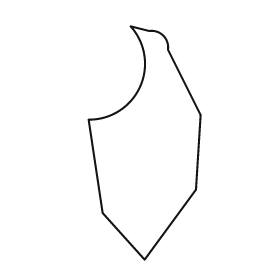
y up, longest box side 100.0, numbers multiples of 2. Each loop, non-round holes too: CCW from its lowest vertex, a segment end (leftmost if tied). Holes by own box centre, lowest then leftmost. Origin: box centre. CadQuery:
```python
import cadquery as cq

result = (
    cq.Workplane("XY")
    .moveTo(0.0, -50.0)
    .lineTo(22.0, -20.0)
    .lineTo(24.0, 12.0)
    .lineTo(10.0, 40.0)
    .threePointArc((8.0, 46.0), (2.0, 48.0))
    .lineTo(-6.0, 50.0)
    .threePointArc((-2.0, 24.0), (-24.0, 10.0))
    .lineTo(-18.0, -30.0)
    .close()
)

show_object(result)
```